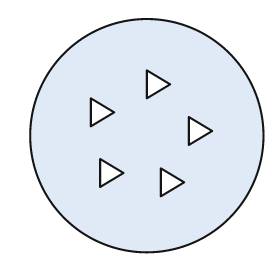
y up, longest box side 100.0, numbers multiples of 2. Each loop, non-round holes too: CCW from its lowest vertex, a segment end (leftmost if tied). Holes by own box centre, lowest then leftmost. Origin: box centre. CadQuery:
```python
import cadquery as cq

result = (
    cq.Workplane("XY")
    .moveTo(0.0, 0.0)
    .circle(50.0)
    .moveTo(6.0, -26.0)
    .lineTo(16.0, -20.0)
    .lineTo(6.0, -14.0)
    .close()
    .moveTo(-20.0, -22.0)
    .lineTo(-10.0, -16.0)
    .lineTo(-20.0, -10.0)
    .close()
    .moveTo(18.0, -4.0)
    .lineTo(28.0, 2.0)
    .lineTo(18.0, 8.0)
    .close()
    .moveTo(-24.0, 4.0)
    .lineTo(-14.0, 10.0)
    .lineTo(-24.0, 16.0)
    .close()
    .moveTo(0.0, 16.0)
    .lineTo(10.0, 22.0)
    .lineTo(0.0, 28.0)
    .close()
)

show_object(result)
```